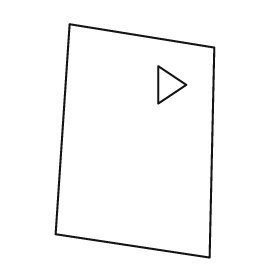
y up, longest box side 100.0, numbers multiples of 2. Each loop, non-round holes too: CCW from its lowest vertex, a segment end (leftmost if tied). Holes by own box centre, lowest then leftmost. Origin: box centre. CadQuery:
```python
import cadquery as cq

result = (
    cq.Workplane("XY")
    .moveTo(32.0, -50.0)
    .lineTo(34.0, 40.0)
    .lineTo(-28.0, 50.0)
    .lineTo(-34.0, -40.0)
    .close()
    .moveTo(10.0, 16.0)
    .lineTo(22.0, 24.0)
    .lineTo(10.0, 32.0)
    .close()
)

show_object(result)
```